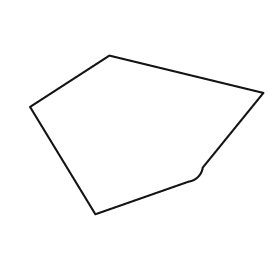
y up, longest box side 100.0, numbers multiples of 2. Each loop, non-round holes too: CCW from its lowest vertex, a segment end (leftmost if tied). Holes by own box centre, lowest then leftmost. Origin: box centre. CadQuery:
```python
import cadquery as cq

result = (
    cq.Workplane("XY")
    .moveTo(-22.0, -34.0)
    .lineTo(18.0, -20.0)
    .threePointArc((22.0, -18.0), (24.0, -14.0))
    .lineTo(50.0, 18.0)
    .lineTo(-16.0, 34.0)
    .lineTo(-50.0, 12.0)
    .close()
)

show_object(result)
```